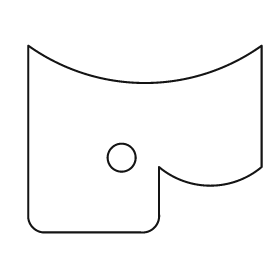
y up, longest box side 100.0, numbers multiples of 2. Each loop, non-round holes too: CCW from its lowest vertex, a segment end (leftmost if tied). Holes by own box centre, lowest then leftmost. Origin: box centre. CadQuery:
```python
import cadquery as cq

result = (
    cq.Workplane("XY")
    .moveTo(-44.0, -40.0)
    .lineTo(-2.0, -40.0)
    .threePointArc((4.0, -38.0), (6.0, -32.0))
    .lineTo(6.0, -12.0)
    .threePointArc((28.0, -20.0), (50.0, -12.0))
    .lineTo(50.0, 40.0)
    .threePointArc((0.0, 24.0), (-50.0, 40.0))
    .lineTo(-50.0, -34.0)
    .threePointArc((-48.0, -38.0), (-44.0, -40.0))
    .close()
    .moveTo(-10.0, -8.0)
    .circle(6.0)
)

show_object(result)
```